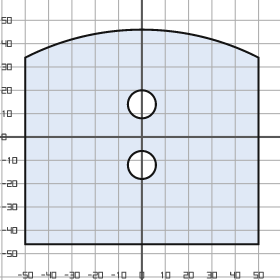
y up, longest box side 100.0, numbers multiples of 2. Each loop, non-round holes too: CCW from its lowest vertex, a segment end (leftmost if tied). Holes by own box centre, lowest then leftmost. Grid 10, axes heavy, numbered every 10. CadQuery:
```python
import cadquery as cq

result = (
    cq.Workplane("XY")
    .moveTo(-50.0, -46.0)
    .lineTo(50.0, -46.0)
    .lineTo(50.0, 34.0)
    .threePointArc((0.0, 46.0), (-50.0, 34.0))
    .close()
    .moveTo(0.0, -12.0)
    .circle(6.0)
    .moveTo(0.0, 14.0)
    .circle(6.0)
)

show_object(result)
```